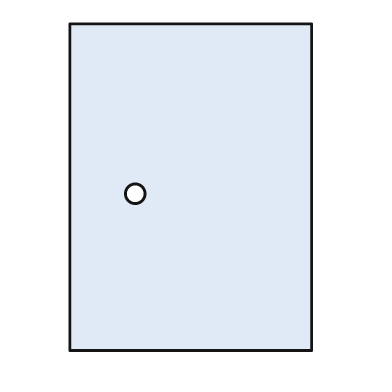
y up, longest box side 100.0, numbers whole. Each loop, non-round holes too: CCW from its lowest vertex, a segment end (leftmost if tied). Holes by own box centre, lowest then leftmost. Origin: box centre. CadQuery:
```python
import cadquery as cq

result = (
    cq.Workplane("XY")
    .moveTo(-37.0, -50.0)
    .lineTo(37.0, -50.0)
    .lineTo(37.0, 50.0)
    .lineTo(-37.0, 50.0)
    .close()
    .moveTo(-17.0, -2.0)
    .circle(3.0)
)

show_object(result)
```